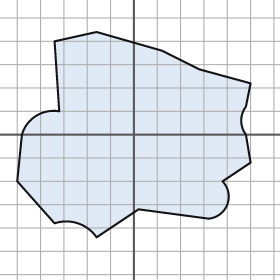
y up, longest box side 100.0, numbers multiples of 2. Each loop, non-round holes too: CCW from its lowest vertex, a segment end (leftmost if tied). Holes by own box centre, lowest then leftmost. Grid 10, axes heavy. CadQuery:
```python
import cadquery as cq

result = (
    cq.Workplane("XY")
    .moveTo(-16.0, -44.0)
    .lineTo(2.0, -32.0)
    .lineTo(32.0, -36.0)
    .threePointArc((40.0, -30.0), (38.0, -20.0))
    .lineTo(50.0, -12.0)
    .lineTo(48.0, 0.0)
    .threePointArc((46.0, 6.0), (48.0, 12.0))
    .lineTo(50.0, 22.0)
    .lineTo(28.0, 28.0)
    .lineTo(12.0, 36.0)
    .lineTo(-16.0, 44.0)
    .lineTo(-34.0, 40.0)
    .lineTo(-32.0, 10.0)
    .threePointArc((-42.0, 8.0), (-48.0, 0.0))
    .lineTo(-50.0, -20.0)
    .lineTo(-34.0, -38.0)
    .threePointArc((-24.0, -38.0), (-16.0, -44.0))
    .close()
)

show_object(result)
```